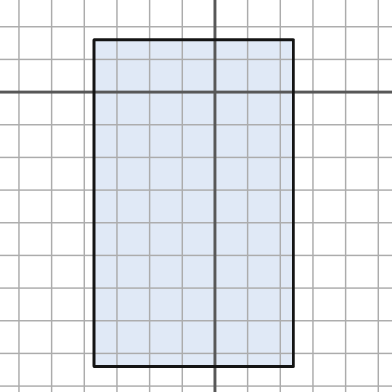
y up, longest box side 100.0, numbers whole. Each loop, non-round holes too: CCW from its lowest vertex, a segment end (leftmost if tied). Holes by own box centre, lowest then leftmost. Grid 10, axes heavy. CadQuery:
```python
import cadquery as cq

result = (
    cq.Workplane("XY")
    .moveTo(-37.0, -84.0)
    .lineTo(24.0, -84.0)
    .lineTo(24.0, 16.0)
    .lineTo(-37.0, 16.0)
    .close()
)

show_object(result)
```